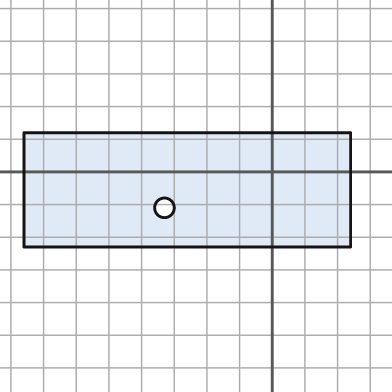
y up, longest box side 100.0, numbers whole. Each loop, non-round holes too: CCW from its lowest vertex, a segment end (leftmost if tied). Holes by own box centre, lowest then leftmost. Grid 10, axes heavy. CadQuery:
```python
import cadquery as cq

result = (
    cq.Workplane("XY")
    .moveTo(-76.0, -23.0)
    .lineTo(24.0, -23.0)
    .lineTo(24.0, 12.0)
    .lineTo(-76.0, 12.0)
    .close()
    .moveTo(-33.0, -11.0)
    .circle(3.0)
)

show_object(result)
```